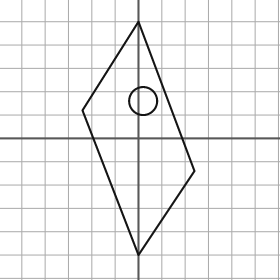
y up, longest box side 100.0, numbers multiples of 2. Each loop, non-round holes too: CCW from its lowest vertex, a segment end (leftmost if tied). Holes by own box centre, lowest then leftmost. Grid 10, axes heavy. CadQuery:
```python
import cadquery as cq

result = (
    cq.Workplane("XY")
    .moveTo(0.0, -50.0)
    .lineTo(24.0, -14.0)
    .lineTo(0.0, 50.0)
    .lineTo(-24.0, 12.0)
    .close()
    .moveTo(2.0, 16.0)
    .circle(6.0)
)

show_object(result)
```